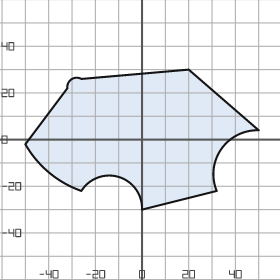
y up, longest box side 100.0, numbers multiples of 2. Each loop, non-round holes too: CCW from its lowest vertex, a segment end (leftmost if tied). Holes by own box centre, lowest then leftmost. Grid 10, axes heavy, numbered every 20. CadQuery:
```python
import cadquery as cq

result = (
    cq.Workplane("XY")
    .moveTo(0.0, -30.0)
    .lineTo(32.0, -22.0)
    .threePointArc((34.0, -4.0), (50.0, 4.0))
    .lineTo(20.0, 30.0)
    .lineTo(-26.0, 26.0)
    .threePointArc((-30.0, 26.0), (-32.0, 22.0))
    .lineTo(-50.0, -2.0)
    .threePointArc((-40.0, -14.0), (-26.0, -22.0))
    .threePointArc((-10.0, -16.0), (0.0, -30.0))
    .close()
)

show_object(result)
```